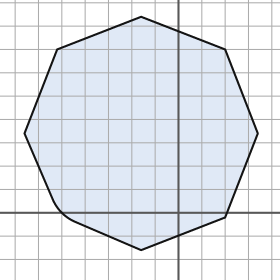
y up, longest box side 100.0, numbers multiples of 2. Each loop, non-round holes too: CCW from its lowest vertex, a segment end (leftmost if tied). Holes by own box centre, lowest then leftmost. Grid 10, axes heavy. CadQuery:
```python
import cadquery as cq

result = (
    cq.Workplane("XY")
    .moveTo(-16.0, -16.0)
    .lineTo(20.0, -2.0)
    .lineTo(34.0, 34.0)
    .lineTo(20.0, 70.0)
    .lineTo(-16.0, 84.0)
    .lineTo(-52.0, 70.0)
    .lineTo(-66.0, 34.0)
    .lineTo(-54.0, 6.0)
    .threePointArc((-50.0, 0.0), (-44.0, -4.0))
    .close()
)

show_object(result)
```